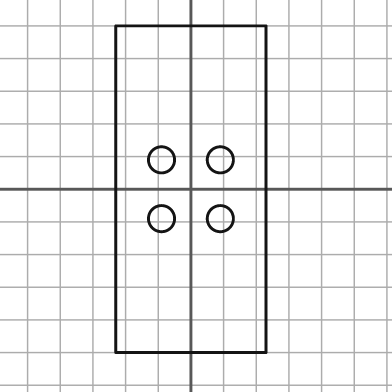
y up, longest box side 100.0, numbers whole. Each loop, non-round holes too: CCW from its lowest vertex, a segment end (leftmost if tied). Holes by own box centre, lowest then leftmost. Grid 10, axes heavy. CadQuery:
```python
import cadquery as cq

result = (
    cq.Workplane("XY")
    .moveTo(-23.0, -50.0)
    .lineTo(23.0, -50.0)
    .lineTo(23.0, 50.0)
    .lineTo(-23.0, 50.0)
    .close()
    .moveTo(-9.0, -9.0)
    .circle(4.0)
    .moveTo(9.0, -9.0)
    .circle(4.0)
    .moveTo(-9.0, 9.0)
    .circle(4.0)
    .moveTo(9.0, 9.0)
    .circle(4.0)
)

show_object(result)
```